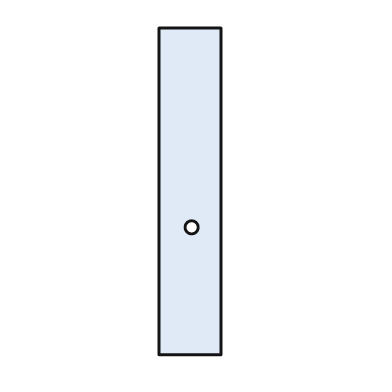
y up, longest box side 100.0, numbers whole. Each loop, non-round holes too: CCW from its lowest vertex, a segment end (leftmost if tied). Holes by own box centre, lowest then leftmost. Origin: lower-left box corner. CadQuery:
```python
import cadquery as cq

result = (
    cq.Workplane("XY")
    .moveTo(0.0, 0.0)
    .lineTo(19.0, 0.0)
    .lineTo(19.0, 100.0)
    .lineTo(0.0, 100.0)
    .close()
    .moveTo(10.0, 39.0)
    .circle(2.0)
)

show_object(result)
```